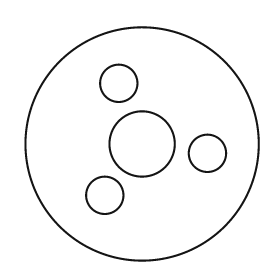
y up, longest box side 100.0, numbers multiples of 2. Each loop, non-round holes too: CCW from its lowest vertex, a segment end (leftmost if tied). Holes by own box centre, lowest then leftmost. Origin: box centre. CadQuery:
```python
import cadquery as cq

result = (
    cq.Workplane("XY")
    .moveTo(0.0, 0.0)
    .circle(50.0)
    .moveTo(-16.0, -22.0)
    .circle(8.0)
    .moveTo(28.0, -4.0)
    .circle(8.0)
    .moveTo(0.0, 0.0)
    .circle(14.0)
    .moveTo(-10.0, 26.0)
    .circle(8.0)
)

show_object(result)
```